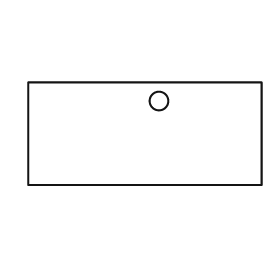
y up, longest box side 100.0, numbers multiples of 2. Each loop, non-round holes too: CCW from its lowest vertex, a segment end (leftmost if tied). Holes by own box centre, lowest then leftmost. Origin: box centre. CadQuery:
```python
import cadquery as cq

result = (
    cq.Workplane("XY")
    .moveTo(-50.0, -22.0)
    .lineTo(50.0, -22.0)
    .lineTo(50.0, 22.0)
    .lineTo(-50.0, 22.0)
    .close()
    .moveTo(6.0, 14.0)
    .circle(4.0)
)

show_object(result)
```